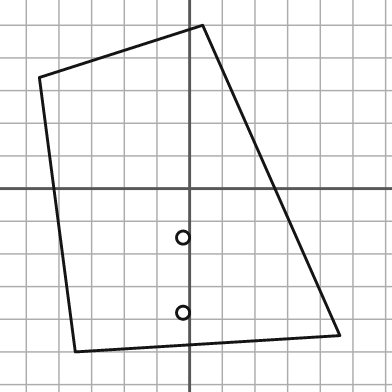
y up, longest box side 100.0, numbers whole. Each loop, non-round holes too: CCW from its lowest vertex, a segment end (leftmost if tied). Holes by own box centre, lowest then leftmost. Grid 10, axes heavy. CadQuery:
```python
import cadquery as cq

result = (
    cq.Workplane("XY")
    .moveTo(-35.0, -50.0)
    .lineTo(46.0, -45.0)
    .lineTo(4.0, 50.0)
    .lineTo(-46.0, 34.0)
    .close()
    .moveTo(-2.0, -38.0)
    .circle(2.0)
    .moveTo(-2.0, -15.0)
    .circle(2.0)
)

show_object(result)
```